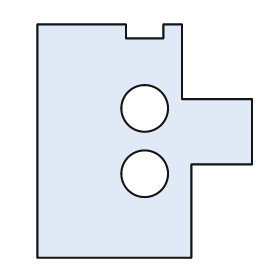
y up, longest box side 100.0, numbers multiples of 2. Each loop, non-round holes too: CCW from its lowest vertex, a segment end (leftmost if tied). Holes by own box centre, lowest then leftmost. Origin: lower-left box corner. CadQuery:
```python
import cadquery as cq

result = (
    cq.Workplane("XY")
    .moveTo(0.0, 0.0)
    .lineTo(66.0, 0.0)
    .lineTo(66.0, 40.0)
    .lineTo(92.0, 40.0)
    .lineTo(92.0, 68.0)
    .lineTo(62.0, 68.0)
    .lineTo(62.0, 100.0)
    .lineTo(54.0, 100.0)
    .lineTo(54.0, 94.0)
    .lineTo(38.0, 94.0)
    .lineTo(38.0, 100.0)
    .lineTo(0.0, 100.0)
    .close()
    .moveTo(46.0, 36.0)
    .circle(10.0)
    .moveTo(46.0, 64.0)
    .circle(10.0)
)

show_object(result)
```